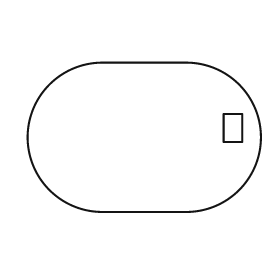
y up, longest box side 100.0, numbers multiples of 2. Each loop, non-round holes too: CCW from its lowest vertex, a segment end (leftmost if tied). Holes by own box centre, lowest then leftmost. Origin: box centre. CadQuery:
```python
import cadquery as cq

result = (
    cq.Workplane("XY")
    .moveTo(-18.0, -32.0)
    .lineTo(18.0, -32.0)
    .threePointArc((50.0, 0.0), (18.0, 32.0))
    .lineTo(-18.0, 32.0)
    .threePointArc((-50.0, 0.0), (-18.0, -32.0))
    .close()
    .moveTo(34.0, -2.0)
    .lineTo(42.0, -2.0)
    .lineTo(42.0, 10.0)
    .lineTo(34.0, 10.0)
    .close()
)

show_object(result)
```